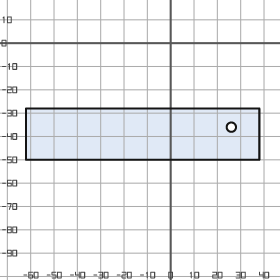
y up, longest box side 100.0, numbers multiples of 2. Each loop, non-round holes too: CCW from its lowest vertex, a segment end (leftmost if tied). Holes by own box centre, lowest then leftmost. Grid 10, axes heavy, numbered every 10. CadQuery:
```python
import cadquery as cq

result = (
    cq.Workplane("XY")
    .moveTo(-62.0, -50.0)
    .lineTo(38.0, -50.0)
    .lineTo(38.0, -28.0)
    .lineTo(-62.0, -28.0)
    .close()
    .moveTo(26.0, -36.0)
    .circle(2.0)
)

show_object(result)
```